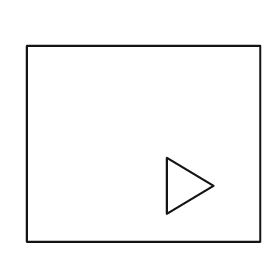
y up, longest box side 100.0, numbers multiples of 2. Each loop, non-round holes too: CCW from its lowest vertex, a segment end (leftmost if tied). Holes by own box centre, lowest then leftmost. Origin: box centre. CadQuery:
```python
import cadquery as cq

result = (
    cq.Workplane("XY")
    .moveTo(-50.0, -42.0)
    .lineTo(50.0, -42.0)
    .lineTo(50.0, 42.0)
    .lineTo(-50.0, 42.0)
    .close()
    .moveTo(10.0, -30.0)
    .lineTo(30.0, -18.0)
    .lineTo(10.0, -6.0)
    .close()
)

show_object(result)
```